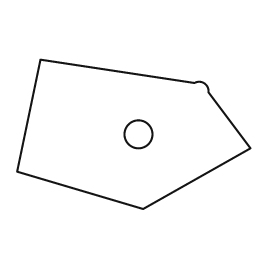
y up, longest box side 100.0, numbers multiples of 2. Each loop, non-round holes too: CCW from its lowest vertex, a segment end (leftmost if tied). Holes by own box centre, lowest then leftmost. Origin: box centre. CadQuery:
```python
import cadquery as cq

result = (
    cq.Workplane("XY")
    .moveTo(4.0, -32.0)
    .lineTo(50.0, -6.0)
    .lineTo(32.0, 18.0)
    .threePointArc((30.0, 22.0), (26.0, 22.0))
    .lineTo(-40.0, 32.0)
    .lineTo(-50.0, -16.0)
    .close()
    .moveTo(2.0, 0.0)
    .circle(6.0)
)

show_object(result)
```